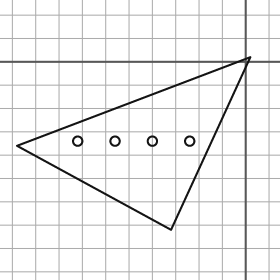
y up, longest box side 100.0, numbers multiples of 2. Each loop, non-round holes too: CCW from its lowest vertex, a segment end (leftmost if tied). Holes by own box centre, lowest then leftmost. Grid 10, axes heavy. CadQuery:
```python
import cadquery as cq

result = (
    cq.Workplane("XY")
    .moveTo(-32.0, -72.0)
    .lineTo(2.0, 2.0)
    .lineTo(-98.0, -36.0)
    .close()
    .moveTo(-72.0, -34.0)
    .circle(2.0)
    .moveTo(-56.0, -34.0)
    .circle(2.0)
    .moveTo(-40.0, -34.0)
    .circle(2.0)
    .moveTo(-24.0, -34.0)
    .circle(2.0)
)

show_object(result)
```